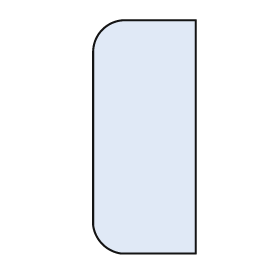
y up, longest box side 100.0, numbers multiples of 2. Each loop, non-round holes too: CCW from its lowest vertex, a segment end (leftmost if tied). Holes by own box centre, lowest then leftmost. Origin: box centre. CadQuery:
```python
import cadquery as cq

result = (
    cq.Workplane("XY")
    .moveTo(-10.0, -50.0)
    .lineTo(22.0, -50.0)
    .lineTo(22.0, 50.0)
    .lineTo(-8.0, 50.0)
    .threePointArc((-18.0, 46.0), (-22.0, 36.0))
    .lineTo(-22.0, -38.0)
    .threePointArc((-18.0, -46.0), (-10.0, -50.0))
    .close()
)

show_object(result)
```